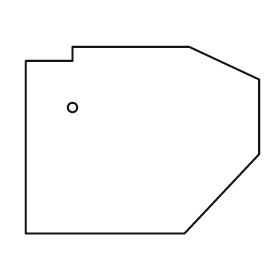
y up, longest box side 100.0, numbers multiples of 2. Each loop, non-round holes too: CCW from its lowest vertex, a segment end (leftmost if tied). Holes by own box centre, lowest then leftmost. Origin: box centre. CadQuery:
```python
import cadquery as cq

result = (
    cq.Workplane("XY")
    .moveTo(-50.0, -40.0)
    .lineTo(18.0, -40.0)
    .lineTo(50.0, -6.0)
    .lineTo(50.0, 26.0)
    .lineTo(20.0, 40.0)
    .lineTo(-30.0, 40.0)
    .lineTo(-30.0, 34.0)
    .lineTo(-50.0, 34.0)
    .close()
    .moveTo(-30.0, 14.0)
    .circle(2.0)
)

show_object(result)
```